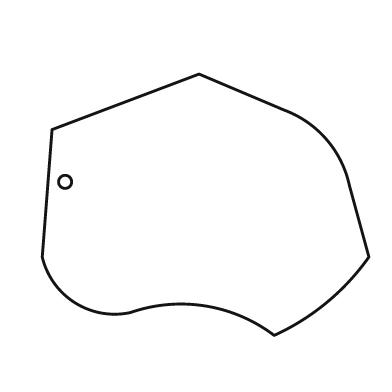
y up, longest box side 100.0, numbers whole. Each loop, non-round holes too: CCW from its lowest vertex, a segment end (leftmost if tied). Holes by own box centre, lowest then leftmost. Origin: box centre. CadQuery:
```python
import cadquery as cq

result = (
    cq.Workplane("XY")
    .moveTo(21.0, -40.0)
    .threePointArc((37.0, -30.0), (50.0, -16.0))
    .lineTo(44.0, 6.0)
    .threePointArc((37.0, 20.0), (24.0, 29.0))
    .lineTo(-2.0, 40.0)
    .lineTo(-47.0, 23.0)
    .lineTo(-50.0, -16.0)
    .threePointArc((-40.0, -30.0), (-23.0, -33.0))
    .threePointArc((0.0, -31.0), (21.0, -40.0))
    .close()
    .moveTo(-43.0, 7.0)
    .circle(2.0)
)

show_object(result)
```